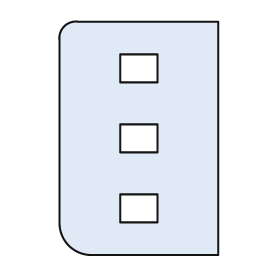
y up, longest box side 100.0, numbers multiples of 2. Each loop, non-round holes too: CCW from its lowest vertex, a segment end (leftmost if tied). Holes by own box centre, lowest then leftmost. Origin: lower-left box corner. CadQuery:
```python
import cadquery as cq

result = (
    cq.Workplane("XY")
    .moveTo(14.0, 0.0)
    .lineTo(68.0, 0.0)
    .lineTo(68.0, 100.0)
    .lineTo(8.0, 100.0)
    .threePointArc((2.0, 98.0), (0.0, 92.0))
    .lineTo(0.0, 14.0)
    .threePointArc((4.0, 4.0), (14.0, 0.0))
    .close()
    .moveTo(26.0, 14.0)
    .lineTo(42.0, 14.0)
    .lineTo(42.0, 26.0)
    .lineTo(26.0, 26.0)
    .close()
    .moveTo(26.0, 44.0)
    .lineTo(42.0, 44.0)
    .lineTo(42.0, 56.0)
    .lineTo(26.0, 56.0)
    .close()
    .moveTo(26.0, 74.0)
    .lineTo(42.0, 74.0)
    .lineTo(42.0, 86.0)
    .lineTo(26.0, 86.0)
    .close()
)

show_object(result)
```